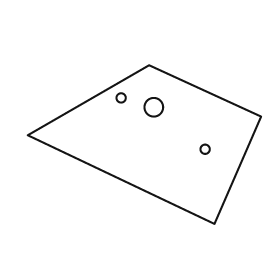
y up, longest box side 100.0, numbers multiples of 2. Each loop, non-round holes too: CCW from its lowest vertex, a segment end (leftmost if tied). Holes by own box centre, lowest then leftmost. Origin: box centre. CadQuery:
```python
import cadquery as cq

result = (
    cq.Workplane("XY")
    .moveTo(30.0, -34.0)
    .lineTo(50.0, 12.0)
    .lineTo(2.0, 34.0)
    .lineTo(-50.0, 4.0)
    .close()
    .moveTo(26.0, -2.0)
    .circle(2.0)
    .moveTo(4.0, 16.0)
    .circle(4.0)
    .moveTo(-10.0, 20.0)
    .circle(2.0)
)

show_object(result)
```